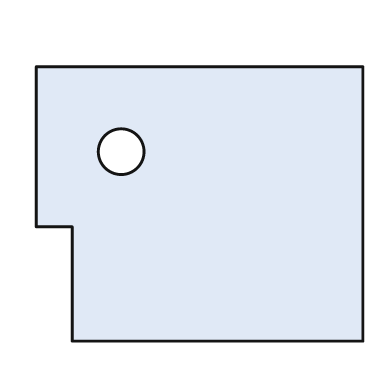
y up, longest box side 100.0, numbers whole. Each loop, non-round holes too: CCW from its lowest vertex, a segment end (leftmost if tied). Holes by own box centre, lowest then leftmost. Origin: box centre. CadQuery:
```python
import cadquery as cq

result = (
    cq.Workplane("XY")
    .moveTo(-39.0, -42.0)
    .lineTo(50.0, -42.0)
    .lineTo(50.0, 42.0)
    .lineTo(-50.0, 42.0)
    .lineTo(-50.0, -7.0)
    .lineTo(-39.0, -7.0)
    .close()
    .moveTo(-24.0, 16.0)
    .circle(7.0)
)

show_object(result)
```